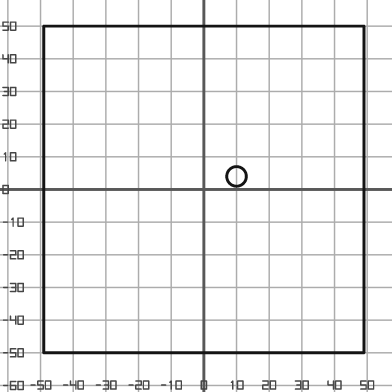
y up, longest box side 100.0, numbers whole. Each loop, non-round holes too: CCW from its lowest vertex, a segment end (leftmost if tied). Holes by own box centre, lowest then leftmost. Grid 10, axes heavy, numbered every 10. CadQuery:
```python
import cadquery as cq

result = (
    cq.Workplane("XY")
    .moveTo(-49.0, -50.0)
    .lineTo(49.0, -50.0)
    .lineTo(49.0, 50.0)
    .lineTo(-49.0, 50.0)
    .close()
    .moveTo(10.0, 4.0)
    .circle(3.0)
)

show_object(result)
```